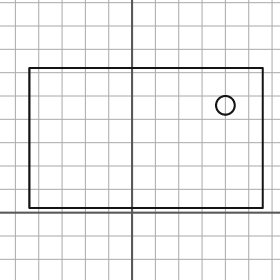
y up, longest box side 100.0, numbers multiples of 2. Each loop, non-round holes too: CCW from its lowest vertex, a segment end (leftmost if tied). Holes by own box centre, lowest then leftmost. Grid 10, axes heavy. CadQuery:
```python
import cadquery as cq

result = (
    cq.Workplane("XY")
    .moveTo(-44.0, 2.0)
    .lineTo(56.0, 2.0)
    .lineTo(56.0, 62.0)
    .lineTo(-44.0, 62.0)
    .close()
    .moveTo(40.0, 46.0)
    .circle(4.0)
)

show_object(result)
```